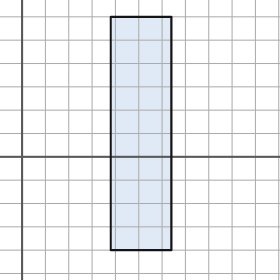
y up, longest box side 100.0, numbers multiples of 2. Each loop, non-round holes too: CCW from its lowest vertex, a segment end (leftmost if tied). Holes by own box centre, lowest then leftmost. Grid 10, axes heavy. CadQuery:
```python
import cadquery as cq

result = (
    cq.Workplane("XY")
    .moveTo(38.0, -40.0)
    .lineTo(64.0, -40.0)
    .lineTo(64.0, 60.0)
    .lineTo(38.0, 60.0)
    .close()
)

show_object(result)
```